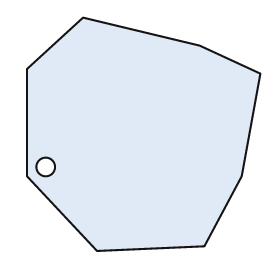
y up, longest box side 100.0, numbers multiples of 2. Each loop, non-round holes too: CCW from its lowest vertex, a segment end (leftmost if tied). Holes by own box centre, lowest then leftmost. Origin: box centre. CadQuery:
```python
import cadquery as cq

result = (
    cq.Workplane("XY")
    .moveTo(-20.0, -50.0)
    .lineTo(26.0, -48.0)
    .lineTo(42.0, -18.0)
    .lineTo(50.0, 26.0)
    .lineTo(24.0, 38.0)
    .lineTo(-26.0, 50.0)
    .lineTo(-50.0, 28.0)
    .lineTo(-50.0, -18.0)
    .close()
    .moveTo(-42.0, -14.0)
    .circle(4.0)
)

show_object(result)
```